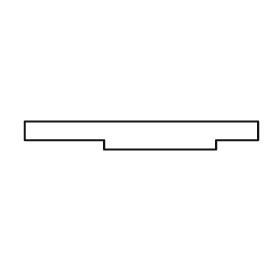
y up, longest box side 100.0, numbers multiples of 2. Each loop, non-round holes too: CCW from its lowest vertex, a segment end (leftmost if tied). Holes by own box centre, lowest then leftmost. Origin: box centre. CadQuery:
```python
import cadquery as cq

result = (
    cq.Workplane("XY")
    .moveTo(-16.0, -6.0)
    .lineTo(32.0, -6.0)
    .lineTo(32.0, -2.0)
    .lineTo(50.0, -2.0)
    .lineTo(50.0, 6.0)
    .lineTo(-50.0, 6.0)
    .lineTo(-50.0, -2.0)
    .lineTo(-16.0, -2.0)
    .close()
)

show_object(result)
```